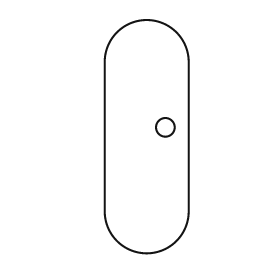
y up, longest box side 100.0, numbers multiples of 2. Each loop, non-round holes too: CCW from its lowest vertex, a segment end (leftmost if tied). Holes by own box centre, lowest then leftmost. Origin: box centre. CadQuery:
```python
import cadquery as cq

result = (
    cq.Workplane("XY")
    .moveTo(-18.0, -32.0)
    .threePointArc((0.0, -50.0), (18.0, -32.0))
    .lineTo(18.0, 32.0)
    .threePointArc((0.0, 50.0), (-18.0, 32.0))
    .close()
    .moveTo(8.0, 4.0)
    .circle(4.0)
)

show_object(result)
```